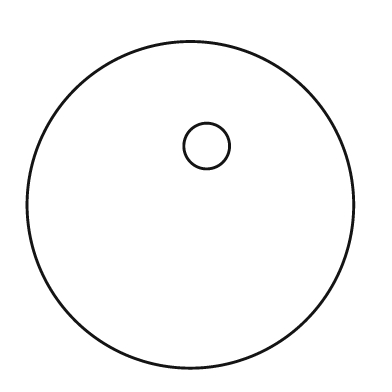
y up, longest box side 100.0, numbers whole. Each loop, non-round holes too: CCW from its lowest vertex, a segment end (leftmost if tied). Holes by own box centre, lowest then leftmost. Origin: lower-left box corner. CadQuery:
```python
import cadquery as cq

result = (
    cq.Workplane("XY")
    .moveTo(50.0, 50.0)
    .circle(50.0)
    .moveTo(55.0, 68.0)
    .circle(7.0)
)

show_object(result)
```